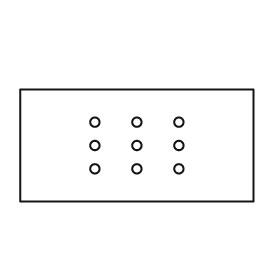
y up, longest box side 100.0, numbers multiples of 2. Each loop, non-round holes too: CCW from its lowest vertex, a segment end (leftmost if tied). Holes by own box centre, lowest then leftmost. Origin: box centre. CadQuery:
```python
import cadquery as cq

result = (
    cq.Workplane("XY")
    .moveTo(-50.0, -24.0)
    .lineTo(50.0, -24.0)
    .lineTo(50.0, 24.0)
    .lineTo(-50.0, 24.0)
    .close()
    .moveTo(-18.0, -10.0)
    .circle(2.0)
    .moveTo(0.0, -10.0)
    .circle(2.0)
    .moveTo(18.0, -10.0)
    .circle(2.0)
    .moveTo(-18.0, 0.0)
    .circle(2.0)
    .moveTo(0.0, 0.0)
    .circle(2.0)
    .moveTo(18.0, 0.0)
    .circle(2.0)
    .moveTo(-18.0, 10.0)
    .circle(2.0)
    .moveTo(0.0, 10.0)
    .circle(2.0)
    .moveTo(18.0, 10.0)
    .circle(2.0)
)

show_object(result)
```